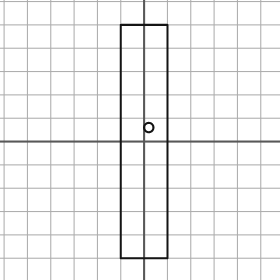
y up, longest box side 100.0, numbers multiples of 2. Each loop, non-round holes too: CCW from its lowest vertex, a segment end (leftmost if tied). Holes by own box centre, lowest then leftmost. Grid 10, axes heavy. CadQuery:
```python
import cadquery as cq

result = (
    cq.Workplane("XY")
    .moveTo(-10.0, -50.0)
    .lineTo(10.0, -50.0)
    .lineTo(10.0, 50.0)
    .lineTo(-10.0, 50.0)
    .close()
    .moveTo(2.0, 6.0)
    .circle(2.0)
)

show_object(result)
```